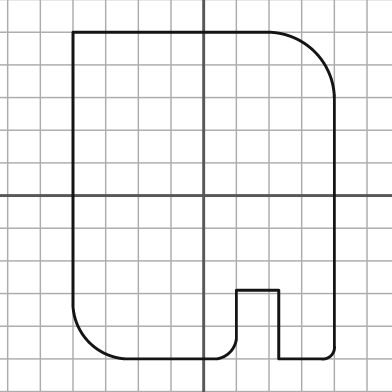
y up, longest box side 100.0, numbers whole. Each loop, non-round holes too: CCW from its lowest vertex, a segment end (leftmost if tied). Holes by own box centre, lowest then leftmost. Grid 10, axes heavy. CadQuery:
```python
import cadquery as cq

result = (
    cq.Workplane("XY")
    .moveTo(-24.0, -50.0)
    .lineTo(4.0, -50.0)
    .threePointArc((8.0, -48.0), (10.0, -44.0))
    .lineTo(10.0, -29.0)
    .lineTo(23.0, -29.0)
    .lineTo(23.0, -50.0)
    .lineTo(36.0, -50.0)
    .threePointArc((39.0, -49.0), (40.0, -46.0))
    .lineTo(40.0, 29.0)
    .threePointArc((34.0, 44.0), (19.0, 50.0))
    .lineTo(-40.0, 50.0)
    .lineTo(-40.0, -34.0)
    .threePointArc((-35.0, -45.0), (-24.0, -50.0))
    .close()
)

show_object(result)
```